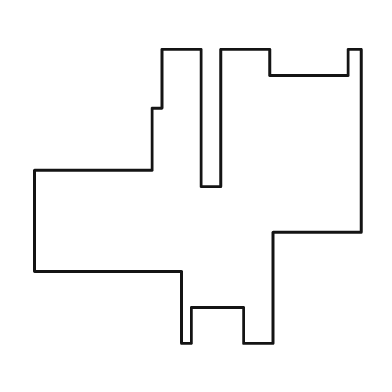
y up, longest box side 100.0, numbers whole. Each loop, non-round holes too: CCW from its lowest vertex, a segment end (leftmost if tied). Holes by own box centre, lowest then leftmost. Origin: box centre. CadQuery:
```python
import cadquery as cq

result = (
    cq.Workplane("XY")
    .moveTo(-5.0, -45.0)
    .lineTo(-2.0, -45.0)
    .lineTo(-2.0, -34.0)
    .lineTo(14.0, -34.0)
    .lineTo(14.0, -45.0)
    .lineTo(23.0, -45.0)
    .lineTo(23.0, -11.0)
    .lineTo(50.0, -11.0)
    .lineTo(50.0, 45.0)
    .lineTo(46.0, 45.0)
    .lineTo(46.0, 37.0)
    .lineTo(22.0, 37.0)
    .lineTo(22.0, 45.0)
    .lineTo(7.0, 45.0)
    .lineTo(7.0, 3.0)
    .lineTo(1.0, 3.0)
    .lineTo(1.0, 45.0)
    .lineTo(-11.0, 45.0)
    .lineTo(-11.0, 27.0)
    .lineTo(-14.0, 27.0)
    .lineTo(-14.0, 8.0)
    .lineTo(-50.0, 8.0)
    .lineTo(-50.0, -23.0)
    .lineTo(-5.0, -23.0)
    .close()
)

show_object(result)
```